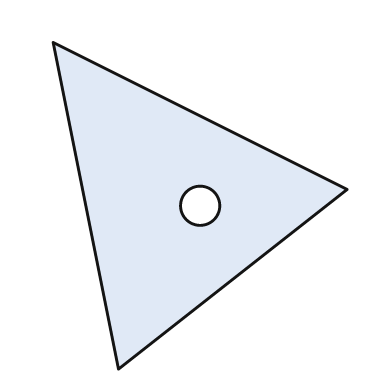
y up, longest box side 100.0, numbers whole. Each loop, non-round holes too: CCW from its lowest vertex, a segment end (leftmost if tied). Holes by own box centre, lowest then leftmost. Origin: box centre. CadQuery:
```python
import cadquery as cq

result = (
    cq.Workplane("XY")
    .moveTo(-25.0, -50.0)
    .lineTo(45.0, 5.0)
    .lineTo(-45.0, 50.0)
    .close()
    .moveTo(0.0, 0.0)
    .circle(6.0)
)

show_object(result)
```